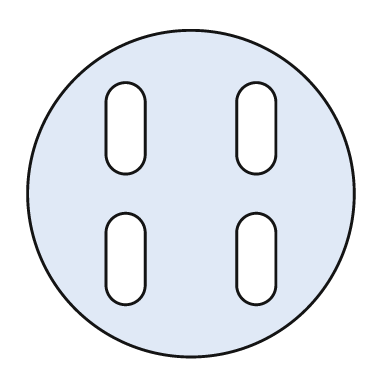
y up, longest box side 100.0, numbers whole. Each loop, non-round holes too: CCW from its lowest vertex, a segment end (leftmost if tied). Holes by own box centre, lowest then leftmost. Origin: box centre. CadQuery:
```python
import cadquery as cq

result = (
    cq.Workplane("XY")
    .moveTo(0.0, 0.0)
    .circle(50.0)
    .moveTo(-26.0, -28.0)
    .threePointArc((-20.0, -34.0), (-14.0, -28.0))
    .lineTo(-14.0, -12.0)
    .threePointArc((-20.0, -6.0), (-26.0, -12.0))
    .close()
    .moveTo(14.0, -28.0)
    .threePointArc((20.0, -34.0), (26.0, -28.0))
    .lineTo(26.0, -12.0)
    .threePointArc((20.0, -6.0), (14.0, -12.0))
    .close()
    .moveTo(-26.0, 12.0)
    .threePointArc((-20.0, 6.0), (-14.0, 12.0))
    .lineTo(-14.0, 28.0)
    .threePointArc((-20.0, 34.0), (-26.0, 28.0))
    .close()
    .moveTo(14.0, 12.0)
    .threePointArc((20.0, 6.0), (26.0, 12.0))
    .lineTo(26.0, 28.0)
    .threePointArc((20.0, 34.0), (14.0, 28.0))
    .close()
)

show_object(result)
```